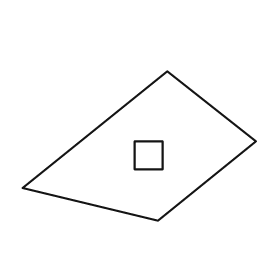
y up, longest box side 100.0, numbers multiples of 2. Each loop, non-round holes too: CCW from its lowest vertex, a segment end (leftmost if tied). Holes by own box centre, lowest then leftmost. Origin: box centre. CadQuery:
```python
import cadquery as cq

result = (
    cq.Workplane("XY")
    .moveTo(8.0, -32.0)
    .lineTo(50.0, 2.0)
    .lineTo(12.0, 32.0)
    .lineTo(-50.0, -18.0)
    .close()
    .moveTo(-2.0, -10.0)
    .lineTo(10.0, -10.0)
    .lineTo(10.0, 2.0)
    .lineTo(-2.0, 2.0)
    .close()
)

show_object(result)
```